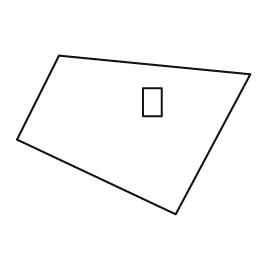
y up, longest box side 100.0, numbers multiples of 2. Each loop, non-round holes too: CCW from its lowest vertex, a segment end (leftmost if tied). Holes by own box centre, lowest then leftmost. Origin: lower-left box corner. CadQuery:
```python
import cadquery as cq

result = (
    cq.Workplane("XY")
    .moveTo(68.0, 0.0)
    .lineTo(100.0, 60.0)
    .lineTo(18.0, 68.0)
    .lineTo(0.0, 32.0)
    .close()
    .moveTo(54.0, 42.0)
    .lineTo(62.0, 42.0)
    .lineTo(62.0, 54.0)
    .lineTo(54.0, 54.0)
    .close()
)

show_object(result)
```